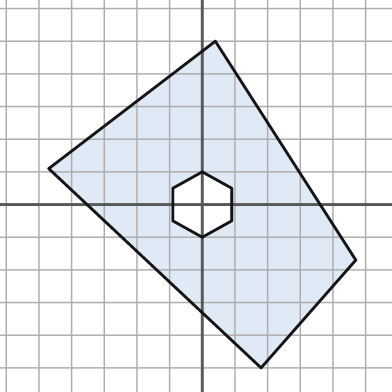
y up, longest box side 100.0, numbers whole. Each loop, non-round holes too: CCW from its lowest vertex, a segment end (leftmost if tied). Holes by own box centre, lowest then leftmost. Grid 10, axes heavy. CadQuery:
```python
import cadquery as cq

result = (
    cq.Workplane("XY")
    .moveTo(18.0, -50.0)
    .lineTo(47.0, -17.0)
    .lineTo(4.0, 50.0)
    .lineTo(-47.0, 11.0)
    .close()
    .moveTo(0.0, -10.0)
    .lineTo(9.0, -5.0)
    .lineTo(9.0, 5.0)
    .lineTo(0.0, 10.0)
    .lineTo(-9.0, 5.0)
    .lineTo(-9.0, -5.0)
    .close()
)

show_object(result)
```